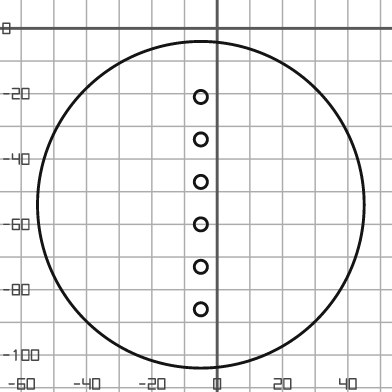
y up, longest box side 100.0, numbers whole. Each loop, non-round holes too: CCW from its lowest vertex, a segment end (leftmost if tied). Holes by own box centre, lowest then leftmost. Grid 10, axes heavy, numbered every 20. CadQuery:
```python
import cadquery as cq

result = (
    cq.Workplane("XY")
    .moveTo(-5.0, -54.0)
    .circle(50.0)
    .moveTo(-5.0, -86.0)
    .circle(2.0)
    .moveTo(-5.0, -73.0)
    .circle(2.0)
    .moveTo(-5.0, -60.0)
    .circle(2.0)
    .moveTo(-5.0, -47.0)
    .circle(2.0)
    .moveTo(-5.0, -34.0)
    .circle(2.0)
    .moveTo(-5.0, -21.0)
    .circle(2.0)
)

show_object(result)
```